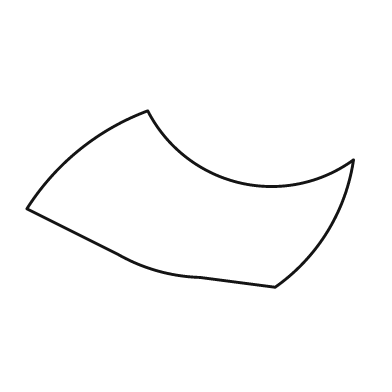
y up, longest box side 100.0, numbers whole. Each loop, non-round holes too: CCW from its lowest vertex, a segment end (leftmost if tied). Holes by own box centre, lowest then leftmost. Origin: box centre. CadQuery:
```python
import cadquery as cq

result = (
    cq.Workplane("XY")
    .moveTo(26.0, -27.0)
    .threePointArc((42.0, -10.0), (50.0, 12.0))
    .threePointArc((15.0, 5.0), (-13.0, 27.0))
    .threePointArc((-34.0, 15.0), (-50.0, -3.0))
    .lineTo(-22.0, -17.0)
    .threePointArc((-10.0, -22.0), (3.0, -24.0))
    .close()
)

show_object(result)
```